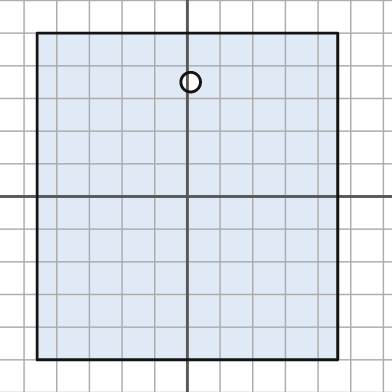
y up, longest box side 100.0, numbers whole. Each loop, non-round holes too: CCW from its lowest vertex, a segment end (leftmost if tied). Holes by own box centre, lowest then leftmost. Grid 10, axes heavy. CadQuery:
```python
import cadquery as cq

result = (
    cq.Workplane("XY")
    .moveTo(-46.0, -50.0)
    .lineTo(46.0, -50.0)
    .lineTo(46.0, 50.0)
    .lineTo(-46.0, 50.0)
    .close()
    .moveTo(1.0, 35.0)
    .circle(3.0)
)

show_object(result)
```